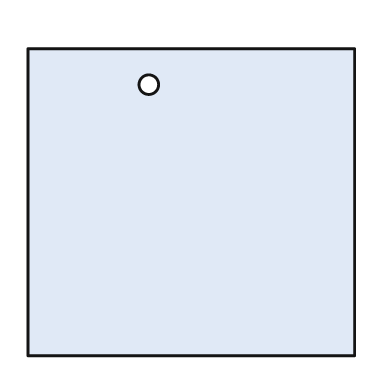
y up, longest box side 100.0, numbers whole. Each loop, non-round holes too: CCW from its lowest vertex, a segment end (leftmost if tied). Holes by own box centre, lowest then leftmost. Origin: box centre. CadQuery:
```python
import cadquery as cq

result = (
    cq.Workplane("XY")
    .moveTo(-50.0, -47.0)
    .lineTo(50.0, -47.0)
    .lineTo(50.0, 47.0)
    .lineTo(-50.0, 47.0)
    .close()
    .moveTo(-13.0, 36.0)
    .circle(3.0)
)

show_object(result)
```